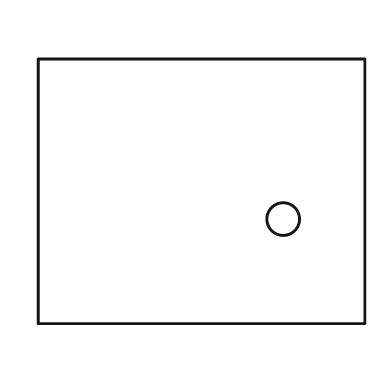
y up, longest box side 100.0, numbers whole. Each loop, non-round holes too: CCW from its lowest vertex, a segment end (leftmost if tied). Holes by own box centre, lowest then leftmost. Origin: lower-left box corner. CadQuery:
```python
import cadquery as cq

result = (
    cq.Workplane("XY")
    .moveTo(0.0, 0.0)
    .lineTo(100.0, 0.0)
    .lineTo(100.0, 81.0)
    .lineTo(0.0, 81.0)
    .close()
    .moveTo(75.0, 32.0)
    .circle(5.0)
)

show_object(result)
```